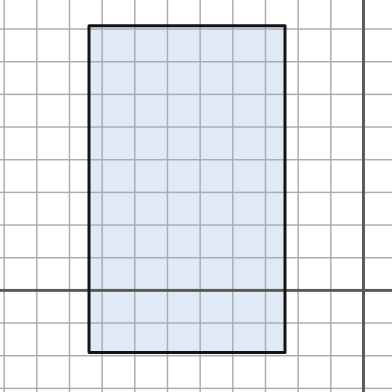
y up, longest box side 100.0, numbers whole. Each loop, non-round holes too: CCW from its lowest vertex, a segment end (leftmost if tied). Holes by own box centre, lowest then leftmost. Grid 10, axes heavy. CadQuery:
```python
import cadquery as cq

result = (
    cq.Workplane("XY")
    .moveTo(-84.0, -19.0)
    .lineTo(-24.0, -19.0)
    .lineTo(-24.0, 81.0)
    .lineTo(-84.0, 81.0)
    .close()
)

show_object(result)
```